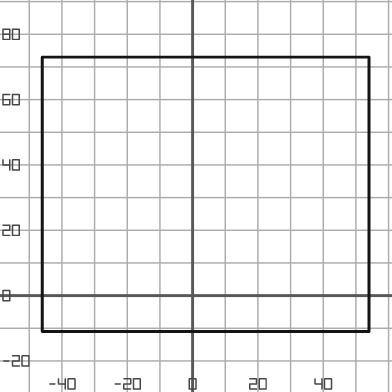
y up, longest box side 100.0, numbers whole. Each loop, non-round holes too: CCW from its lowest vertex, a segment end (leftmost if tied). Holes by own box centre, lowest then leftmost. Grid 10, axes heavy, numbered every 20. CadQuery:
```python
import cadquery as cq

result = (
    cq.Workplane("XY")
    .moveTo(-46.0, -11.0)
    .lineTo(54.0, -11.0)
    .lineTo(54.0, 73.0)
    .lineTo(-46.0, 73.0)
    .close()
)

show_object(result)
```